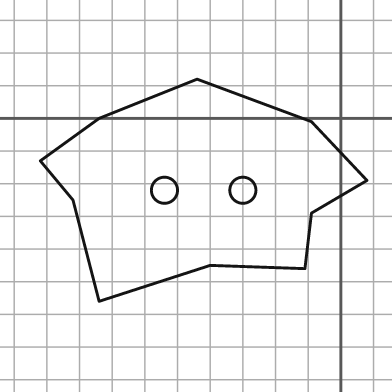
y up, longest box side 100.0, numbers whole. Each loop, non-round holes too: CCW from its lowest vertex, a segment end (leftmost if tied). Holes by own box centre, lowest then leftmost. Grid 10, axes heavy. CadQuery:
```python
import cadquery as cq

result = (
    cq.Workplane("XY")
    .moveTo(-74.0, -56.0)
    .lineTo(-40.0, -45.0)
    .lineTo(-11.0, -46.0)
    .lineTo(-9.0, -29.0)
    .lineTo(8.0, -19.0)
    .lineTo(-9.0, -1.0)
    .lineTo(-44.0, 12.0)
    .lineTo(-74.0, 0.0)
    .lineTo(-92.0, -13.0)
    .lineTo(-82.0, -25.0)
    .close()
    .moveTo(-54.0, -22.0)
    .circle(4.0)
    .moveTo(-30.0, -22.0)
    .circle(4.0)
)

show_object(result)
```